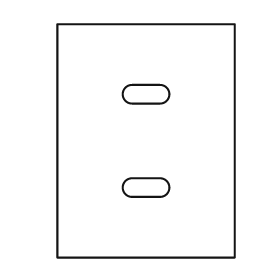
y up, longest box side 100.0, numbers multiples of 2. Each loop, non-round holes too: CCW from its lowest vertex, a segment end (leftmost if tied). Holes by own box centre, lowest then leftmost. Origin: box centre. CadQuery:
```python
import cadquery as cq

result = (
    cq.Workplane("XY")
    .moveTo(-38.0, -50.0)
    .lineTo(38.0, -50.0)
    .lineTo(38.0, 50.0)
    .lineTo(-38.0, 50.0)
    .close()
    .moveTo(-6.0, -24.0)
    .lineTo(6.0, -24.0)
    .threePointArc((10.0, -20.0), (6.0, -16.0))
    .lineTo(-6.0, -16.0)
    .threePointArc((-10.0, -20.0), (-6.0, -24.0))
    .close()
    .moveTo(-6.0, 16.0)
    .lineTo(6.0, 16.0)
    .threePointArc((10.0, 20.0), (6.0, 24.0))
    .lineTo(-6.0, 24.0)
    .threePointArc((-10.0, 20.0), (-6.0, 16.0))
    .close()
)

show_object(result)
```